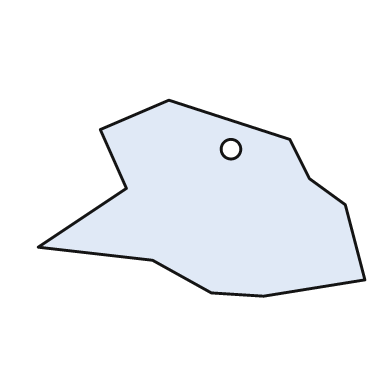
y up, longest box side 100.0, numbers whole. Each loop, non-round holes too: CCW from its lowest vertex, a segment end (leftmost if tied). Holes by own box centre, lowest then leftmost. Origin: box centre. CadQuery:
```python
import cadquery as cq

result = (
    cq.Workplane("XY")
    .moveTo(19.0, -30.0)
    .lineTo(50.0, -25.0)
    .lineTo(44.0, -2.0)
    .lineTo(33.0, 6.0)
    .lineTo(27.0, 18.0)
    .lineTo(-10.0, 30.0)
    .lineTo(-31.0, 21.0)
    .lineTo(-23.0, 3.0)
    .lineTo(-50.0, -15.0)
    .lineTo(-15.0, -19.0)
    .lineTo(3.0, -29.0)
    .close()
    .moveTo(9.0, 15.0)
    .circle(3.0)
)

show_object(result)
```